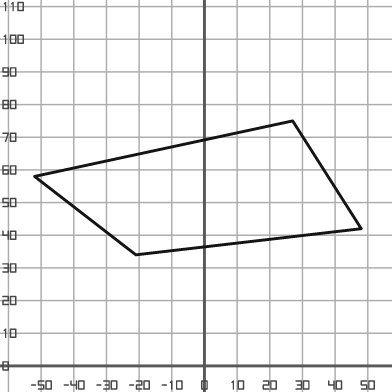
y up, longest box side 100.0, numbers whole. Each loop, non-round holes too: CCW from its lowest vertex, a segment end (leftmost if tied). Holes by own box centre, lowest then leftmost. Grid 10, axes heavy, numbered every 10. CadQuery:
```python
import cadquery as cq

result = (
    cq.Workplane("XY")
    .moveTo(-21.0, 34.0)
    .lineTo(48.0, 42.0)
    .lineTo(27.0, 75.0)
    .lineTo(-52.0, 58.0)
    .close()
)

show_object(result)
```